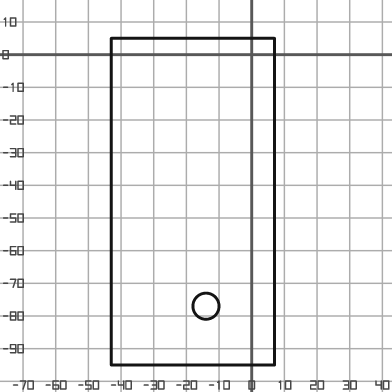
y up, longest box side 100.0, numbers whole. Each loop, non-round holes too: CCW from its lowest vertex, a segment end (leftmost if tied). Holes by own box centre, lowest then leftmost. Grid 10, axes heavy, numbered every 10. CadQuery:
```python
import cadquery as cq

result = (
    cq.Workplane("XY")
    .moveTo(-43.0, -95.0)
    .lineTo(7.0, -95.0)
    .lineTo(7.0, 5.0)
    .lineTo(-43.0, 5.0)
    .close()
    .moveTo(-14.0, -77.0)
    .circle(4.0)
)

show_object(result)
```